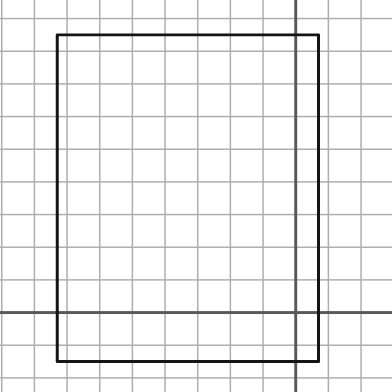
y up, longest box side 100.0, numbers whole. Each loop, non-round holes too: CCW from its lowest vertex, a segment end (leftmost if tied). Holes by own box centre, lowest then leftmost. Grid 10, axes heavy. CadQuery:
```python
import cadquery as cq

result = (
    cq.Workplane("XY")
    .moveTo(-73.0, -15.0)
    .lineTo(7.0, -15.0)
    .lineTo(7.0, 85.0)
    .lineTo(-73.0, 85.0)
    .close()
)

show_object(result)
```